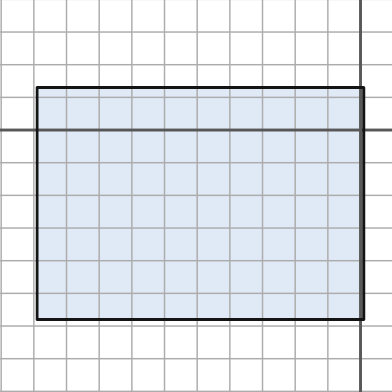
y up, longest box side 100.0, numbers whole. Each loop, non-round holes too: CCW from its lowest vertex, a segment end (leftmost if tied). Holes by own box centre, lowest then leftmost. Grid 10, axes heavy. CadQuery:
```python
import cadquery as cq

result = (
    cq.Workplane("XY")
    .moveTo(-99.0, -58.0)
    .lineTo(1.0, -58.0)
    .lineTo(1.0, 13.0)
    .lineTo(-99.0, 13.0)
    .close()
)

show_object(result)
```